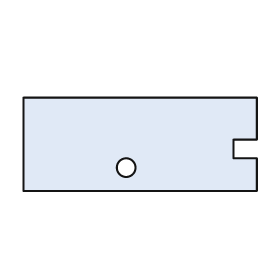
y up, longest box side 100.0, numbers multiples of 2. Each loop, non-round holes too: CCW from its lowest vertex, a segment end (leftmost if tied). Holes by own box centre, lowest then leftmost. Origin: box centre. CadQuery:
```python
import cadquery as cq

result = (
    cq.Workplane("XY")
    .moveTo(-50.0, -20.0)
    .lineTo(50.0, -20.0)
    .lineTo(50.0, -6.0)
    .lineTo(40.0, -6.0)
    .lineTo(40.0, 2.0)
    .lineTo(50.0, 2.0)
    .lineTo(50.0, 20.0)
    .lineTo(-50.0, 20.0)
    .close()
    .moveTo(-6.0, -10.0)
    .circle(4.0)
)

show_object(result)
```